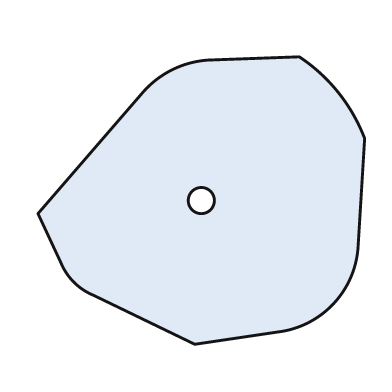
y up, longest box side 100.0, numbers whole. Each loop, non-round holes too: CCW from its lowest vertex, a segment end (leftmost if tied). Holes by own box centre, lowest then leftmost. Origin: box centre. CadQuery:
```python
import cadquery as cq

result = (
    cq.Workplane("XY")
    .moveTo(-2.0, -44.0)
    .lineTo(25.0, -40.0)
    .threePointArc((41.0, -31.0), (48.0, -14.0))
    .lineTo(50.0, 19.0)
    .threePointArc((42.0, 33.0), (30.0, 44.0))
    .lineTo(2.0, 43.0)
    .threePointArc((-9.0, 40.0), (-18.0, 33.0))
    .lineTo(-50.0, -4.0)
    .lineTo(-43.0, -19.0)
    .threePointArc((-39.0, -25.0), (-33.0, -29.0))
    .close()
    .moveTo(0.0, 0.0)
    .circle(4.0)
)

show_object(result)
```